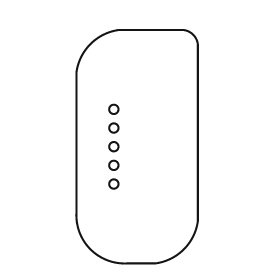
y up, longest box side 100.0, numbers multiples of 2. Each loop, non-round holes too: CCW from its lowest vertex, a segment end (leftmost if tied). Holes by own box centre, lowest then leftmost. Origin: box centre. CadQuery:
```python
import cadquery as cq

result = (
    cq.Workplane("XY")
    .moveTo(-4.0, -50.0)
    .lineTo(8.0, -50.0)
    .threePointArc((20.0, -44.0), (26.0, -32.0))
    .lineTo(26.0, 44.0)
    .threePointArc((24.0, 48.0), (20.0, 50.0))
    .lineTo(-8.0, 50.0)
    .threePointArc((-20.0, 44.0), (-26.0, 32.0))
    .lineTo(-26.0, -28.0)
    .threePointArc((-20.0, -44.0), (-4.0, -50.0))
    .close()
    .moveTo(-10.0, -16.0)
    .circle(2.0)
    .moveTo(-10.0, -8.0)
    .circle(2.0)
    .moveTo(-10.0, 0.0)
    .circle(2.0)
    .moveTo(-10.0, 8.0)
    .circle(2.0)
    .moveTo(-10.0, 16.0)
    .circle(2.0)
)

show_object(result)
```